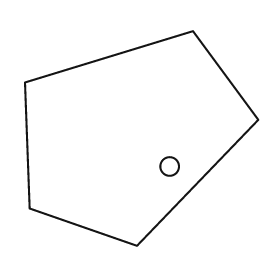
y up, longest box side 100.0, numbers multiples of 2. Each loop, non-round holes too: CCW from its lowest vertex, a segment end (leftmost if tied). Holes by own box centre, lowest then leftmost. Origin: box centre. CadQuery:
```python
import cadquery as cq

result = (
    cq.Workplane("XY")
    .moveTo(-2.0, -46.0)
    .lineTo(50.0, 8.0)
    .lineTo(22.0, 46.0)
    .lineTo(-50.0, 24.0)
    .lineTo(-48.0, -30.0)
    .close()
    .moveTo(12.0, -12.0)
    .circle(4.0)
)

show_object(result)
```